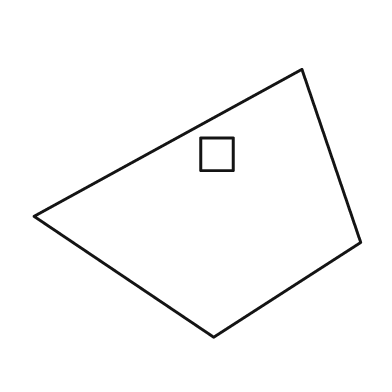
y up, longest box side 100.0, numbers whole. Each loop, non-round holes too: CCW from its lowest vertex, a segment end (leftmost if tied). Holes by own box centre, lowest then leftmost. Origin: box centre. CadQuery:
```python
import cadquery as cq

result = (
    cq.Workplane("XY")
    .moveTo(5.0, -41.0)
    .lineTo(50.0, -12.0)
    .lineTo(32.0, 41.0)
    .lineTo(-50.0, -4.0)
    .close()
    .moveTo(1.0, 10.0)
    .lineTo(11.0, 10.0)
    .lineTo(11.0, 20.0)
    .lineTo(1.0, 20.0)
    .close()
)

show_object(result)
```